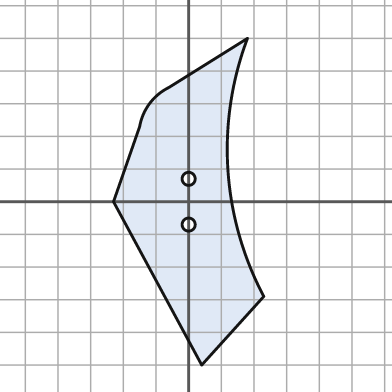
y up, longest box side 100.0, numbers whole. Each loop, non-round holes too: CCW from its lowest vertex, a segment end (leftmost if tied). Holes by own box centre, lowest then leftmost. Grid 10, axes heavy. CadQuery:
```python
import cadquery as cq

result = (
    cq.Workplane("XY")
    .moveTo(4.0, -50.0)
    .lineTo(23.0, -29.0)
    .threePointArc((12.0, 10.0), (18.0, 50.0))
    .lineTo(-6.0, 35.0)
    .threePointArc((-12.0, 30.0), (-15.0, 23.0))
    .lineTo(-23.0, 0.0)
    .close()
    .moveTo(0.0, -7.0)
    .circle(2.0)
    .moveTo(0.0, 7.0)
    .circle(2.0)
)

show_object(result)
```